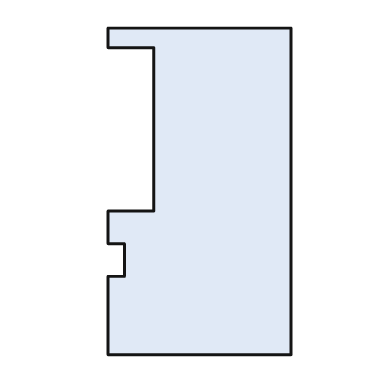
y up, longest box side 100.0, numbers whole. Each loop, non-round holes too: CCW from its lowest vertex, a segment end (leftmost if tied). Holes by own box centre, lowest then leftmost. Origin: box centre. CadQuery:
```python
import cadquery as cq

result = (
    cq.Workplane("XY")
    .moveTo(-28.0, -50.0)
    .lineTo(28.0, -50.0)
    .lineTo(28.0, 50.0)
    .lineTo(-28.0, 50.0)
    .lineTo(-28.0, 44.0)
    .lineTo(-14.0, 44.0)
    .lineTo(-14.0, -6.0)
    .lineTo(-28.0, -6.0)
    .lineTo(-28.0, -16.0)
    .lineTo(-23.0, -16.0)
    .lineTo(-23.0, -26.0)
    .lineTo(-28.0, -26.0)
    .close()
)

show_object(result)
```